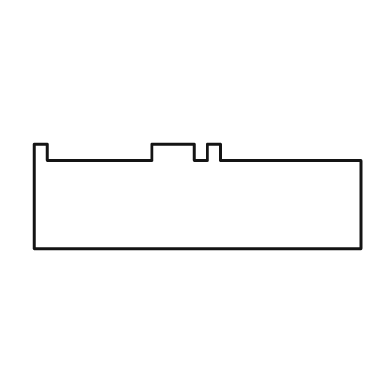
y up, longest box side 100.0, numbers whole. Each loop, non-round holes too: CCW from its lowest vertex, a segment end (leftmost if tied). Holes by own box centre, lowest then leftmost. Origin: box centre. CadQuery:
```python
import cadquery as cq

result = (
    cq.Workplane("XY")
    .moveTo(-50.0, -16.0)
    .lineTo(50.0, -16.0)
    .lineTo(50.0, 11.0)
    .lineTo(7.0, 11.0)
    .lineTo(7.0, 16.0)
    .lineTo(3.0, 16.0)
    .lineTo(3.0, 11.0)
    .lineTo(-1.0, 11.0)
    .lineTo(-1.0, 16.0)
    .lineTo(-14.0, 16.0)
    .lineTo(-14.0, 11.0)
    .lineTo(-46.0, 11.0)
    .lineTo(-46.0, 16.0)
    .lineTo(-50.0, 16.0)
    .close()
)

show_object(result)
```